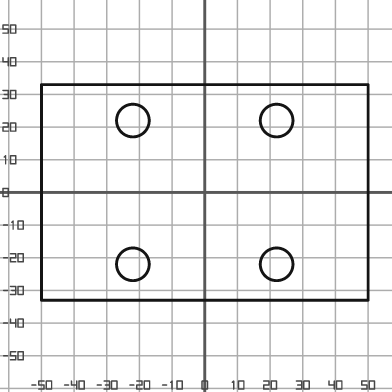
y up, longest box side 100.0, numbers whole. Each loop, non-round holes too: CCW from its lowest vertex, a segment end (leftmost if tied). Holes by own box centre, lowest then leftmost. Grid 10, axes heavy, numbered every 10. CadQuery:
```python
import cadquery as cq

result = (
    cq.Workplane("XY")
    .moveTo(-50.0, -33.0)
    .lineTo(50.0, -33.0)
    .lineTo(50.0, 33.0)
    .lineTo(-50.0, 33.0)
    .close()
    .moveTo(-22.0, -22.0)
    .circle(5.0)
    .moveTo(22.0, -22.0)
    .circle(5.0)
    .moveTo(-22.0, 22.0)
    .circle(5.0)
    .moveTo(22.0, 22.0)
    .circle(5.0)
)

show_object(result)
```